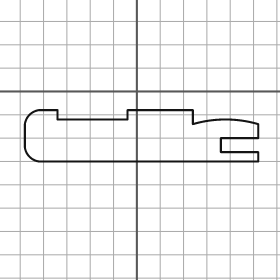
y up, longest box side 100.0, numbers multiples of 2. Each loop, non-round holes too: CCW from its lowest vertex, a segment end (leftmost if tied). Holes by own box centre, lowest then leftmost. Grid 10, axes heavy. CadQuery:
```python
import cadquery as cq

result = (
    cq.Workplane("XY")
    .moveTo(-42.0, -30.0)
    .lineTo(52.0, -30.0)
    .lineTo(52.0, -26.0)
    .lineTo(36.0, -26.0)
    .lineTo(36.0, -20.0)
    .lineTo(52.0, -20.0)
    .lineTo(52.0, -14.0)
    .threePointArc((38.0, -12.0), (24.0, -14.0))
    .lineTo(24.0, -8.0)
    .lineTo(-4.0, -8.0)
    .lineTo(-4.0, -12.0)
    .lineTo(-34.0, -12.0)
    .lineTo(-34.0, -8.0)
    .lineTo(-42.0, -8.0)
    .threePointArc((-46.0, -10.0), (-48.0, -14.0))
    .lineTo(-48.0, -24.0)
    .threePointArc((-46.0, -28.0), (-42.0, -30.0))
    .close()
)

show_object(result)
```